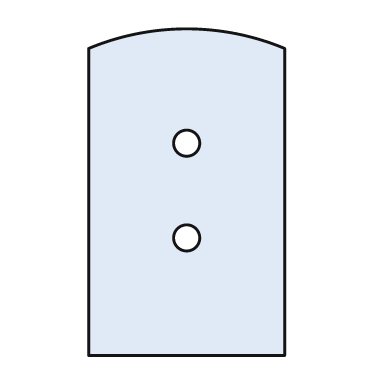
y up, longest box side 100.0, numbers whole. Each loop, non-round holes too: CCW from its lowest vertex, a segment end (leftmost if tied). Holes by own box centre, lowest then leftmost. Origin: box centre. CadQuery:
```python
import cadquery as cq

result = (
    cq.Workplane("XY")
    .moveTo(-30.0, -50.0)
    .lineTo(30.0, -50.0)
    .lineTo(30.0, 44.0)
    .threePointArc((0.0, 50.0), (-30.0, 44.0))
    .close()
    .moveTo(0.0, -14.0)
    .circle(4.0)
    .moveTo(0.0, 15.0)
    .circle(4.0)
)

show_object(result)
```